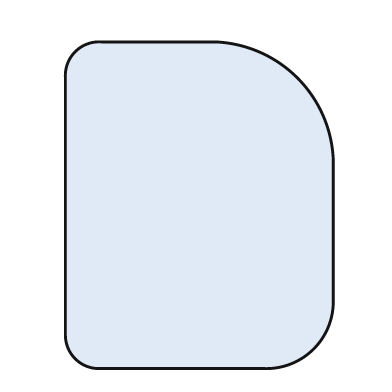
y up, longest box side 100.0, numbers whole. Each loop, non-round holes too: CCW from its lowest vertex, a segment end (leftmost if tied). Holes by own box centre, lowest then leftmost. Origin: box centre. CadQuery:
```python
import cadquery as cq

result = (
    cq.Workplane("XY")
    .moveTo(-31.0, -50.0)
    .lineTo(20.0, -50.0)
    .threePointArc((35.0, -44.0), (41.0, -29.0))
    .lineTo(41.0, 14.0)
    .threePointArc((30.0, 39.0), (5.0, 50.0))
    .lineTo(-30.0, 50.0)
    .threePointArc((-38.0, 47.0), (-41.0, 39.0))
    .lineTo(-41.0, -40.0)
    .threePointArc((-38.0, -47.0), (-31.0, -50.0))
    .close()
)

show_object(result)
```